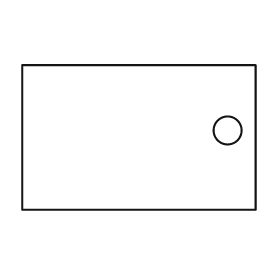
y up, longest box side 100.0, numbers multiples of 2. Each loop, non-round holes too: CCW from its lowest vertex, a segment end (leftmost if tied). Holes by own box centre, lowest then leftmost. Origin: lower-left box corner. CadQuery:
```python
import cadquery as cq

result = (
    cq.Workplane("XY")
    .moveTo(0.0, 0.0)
    .lineTo(100.0, 0.0)
    .lineTo(100.0, 62.0)
    .lineTo(0.0, 62.0)
    .close()
    .moveTo(88.0, 34.0)
    .circle(6.0)
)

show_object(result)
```